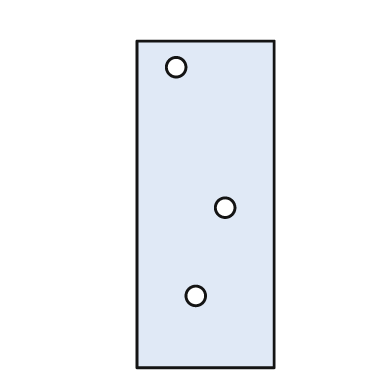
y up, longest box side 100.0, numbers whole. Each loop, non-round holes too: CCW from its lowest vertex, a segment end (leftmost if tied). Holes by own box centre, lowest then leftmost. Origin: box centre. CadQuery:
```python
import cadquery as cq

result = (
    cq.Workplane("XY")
    .moveTo(-21.0, -50.0)
    .lineTo(21.0, -50.0)
    .lineTo(21.0, 50.0)
    .lineTo(-21.0, 50.0)
    .close()
    .moveTo(-3.0, -28.0)
    .circle(3.0)
    .moveTo(6.0, -1.0)
    .circle(3.0)
    .moveTo(-9.0, 42.0)
    .circle(3.0)
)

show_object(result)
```